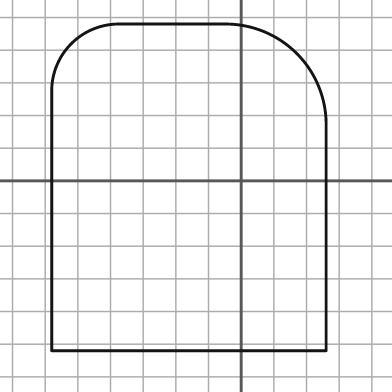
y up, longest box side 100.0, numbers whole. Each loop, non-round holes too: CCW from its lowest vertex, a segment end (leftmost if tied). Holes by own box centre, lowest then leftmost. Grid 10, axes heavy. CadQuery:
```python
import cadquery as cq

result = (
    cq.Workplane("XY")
    .moveTo(-58.0, -52.0)
    .lineTo(26.0, -52.0)
    .lineTo(26.0, 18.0)
    .threePointArc((17.0, 39.0), (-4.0, 48.0))
    .lineTo(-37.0, 48.0)
    .threePointArc((-52.0, 42.0), (-58.0, 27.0))
    .close()
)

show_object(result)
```